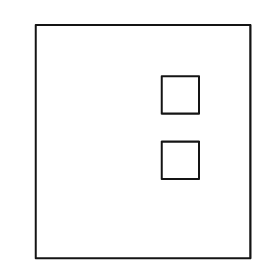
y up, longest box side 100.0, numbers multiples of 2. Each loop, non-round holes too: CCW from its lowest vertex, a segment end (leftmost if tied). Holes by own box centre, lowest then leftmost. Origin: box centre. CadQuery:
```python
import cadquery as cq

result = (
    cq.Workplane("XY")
    .moveTo(-46.0, -50.0)
    .lineTo(46.0, -50.0)
    .lineTo(46.0, 50.0)
    .lineTo(-46.0, 50.0)
    .close()
    .moveTo(8.0, -16.0)
    .lineTo(24.0, -16.0)
    .lineTo(24.0, 0.0)
    .lineTo(8.0, 0.0)
    .close()
    .moveTo(8.0, 12.0)
    .lineTo(24.0, 12.0)
    .lineTo(24.0, 28.0)
    .lineTo(8.0, 28.0)
    .close()
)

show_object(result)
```